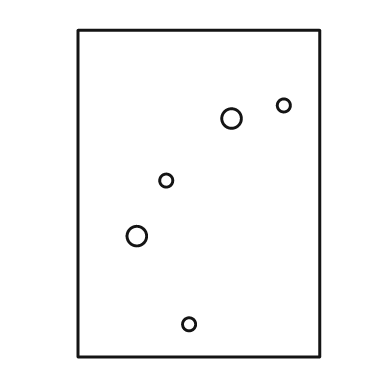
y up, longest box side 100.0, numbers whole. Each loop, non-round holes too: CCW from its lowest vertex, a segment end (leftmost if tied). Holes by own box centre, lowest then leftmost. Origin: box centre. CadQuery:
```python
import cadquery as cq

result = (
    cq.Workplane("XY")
    .moveTo(-37.0, -50.0)
    .lineTo(37.0, -50.0)
    .lineTo(37.0, 50.0)
    .lineTo(-37.0, 50.0)
    .close()
    .moveTo(-3.0, -40.0)
    .circle(2.0)
    .moveTo(-19.0, -13.0)
    .circle(3.0)
    .moveTo(-10.0, 4.0)
    .circle(2.0)
    .moveTo(10.0, 23.0)
    .circle(3.0)
    .moveTo(26.0, 27.0)
    .circle(2.0)
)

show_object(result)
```